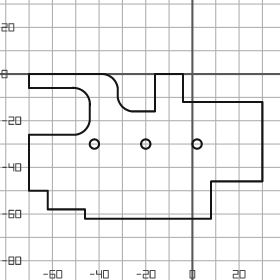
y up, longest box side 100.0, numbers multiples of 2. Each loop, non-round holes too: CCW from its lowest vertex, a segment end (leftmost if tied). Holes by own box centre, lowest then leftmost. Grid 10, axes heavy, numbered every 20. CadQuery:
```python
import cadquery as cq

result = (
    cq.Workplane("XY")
    .moveTo(-46.0, -62.0)
    .lineTo(8.0, -62.0)
    .lineTo(8.0, -46.0)
    .lineTo(30.0, -46.0)
    .lineTo(30.0, -12.0)
    .lineTo(-4.0, -12.0)
    .lineTo(-4.0, 0.0)
    .lineTo(-16.0, 0.0)
    .lineTo(-16.0, -16.0)
    .lineTo(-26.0, -16.0)
    .threePointArc((-30.0, -14.0), (-32.0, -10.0))
    .lineTo(-32.0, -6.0)
    .threePointArc((-34.0, -2.0), (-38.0, 0.0))
    .lineTo(-70.0, 0.0)
    .lineTo(-70.0, -6.0)
    .lineTo(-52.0, -6.0)
    .threePointArc((-46.0, -8.0), (-44.0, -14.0))
    .lineTo(-44.0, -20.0)
    .threePointArc((-46.0, -24.0), (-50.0, -26.0))
    .lineTo(-70.0, -26.0)
    .lineTo(-70.0, -50.0)
    .lineTo(-62.0, -50.0)
    .lineTo(-62.0, -58.0)
    .lineTo(-46.0, -58.0)
    .close()
    .moveTo(-42.0, -30.0)
    .circle(2.0)
    .moveTo(-20.0, -30.0)
    .circle(2.0)
    .moveTo(2.0, -30.0)
    .circle(2.0)
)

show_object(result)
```